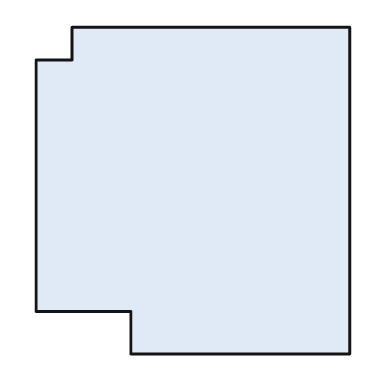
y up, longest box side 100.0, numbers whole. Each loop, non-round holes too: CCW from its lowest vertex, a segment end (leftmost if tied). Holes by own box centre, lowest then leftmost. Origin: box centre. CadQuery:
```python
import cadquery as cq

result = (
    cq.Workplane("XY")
    .moveTo(-19.0, -50.0)
    .lineTo(48.0, -50.0)
    .lineTo(48.0, 50.0)
    .lineTo(-37.0, 50.0)
    .lineTo(-37.0, 40.0)
    .lineTo(-48.0, 40.0)
    .lineTo(-48.0, -37.0)
    .lineTo(-19.0, -37.0)
    .close()
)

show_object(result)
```